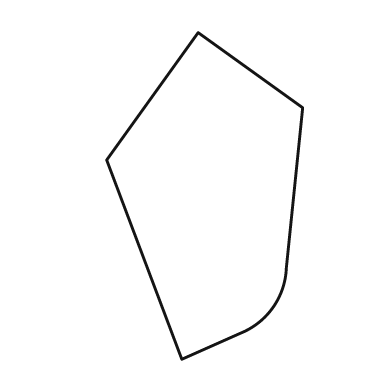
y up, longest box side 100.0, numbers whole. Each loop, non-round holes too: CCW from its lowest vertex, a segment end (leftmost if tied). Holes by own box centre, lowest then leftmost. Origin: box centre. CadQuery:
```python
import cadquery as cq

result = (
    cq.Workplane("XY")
    .moveTo(-7.0, -50.0)
    .lineTo(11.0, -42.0)
    .threePointArc((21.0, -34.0), (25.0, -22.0))
    .lineTo(30.0, 27.0)
    .lineTo(-2.0, 50.0)
    .lineTo(-30.0, 11.0)
    .close()
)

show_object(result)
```